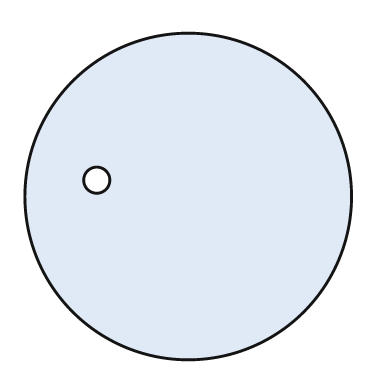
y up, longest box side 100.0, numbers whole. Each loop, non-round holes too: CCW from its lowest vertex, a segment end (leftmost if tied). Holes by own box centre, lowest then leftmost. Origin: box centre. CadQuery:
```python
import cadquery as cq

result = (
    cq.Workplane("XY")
    .moveTo(0.0, 0.0)
    .circle(50.0)
    .moveTo(-28.0, 5.0)
    .circle(4.0)
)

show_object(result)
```